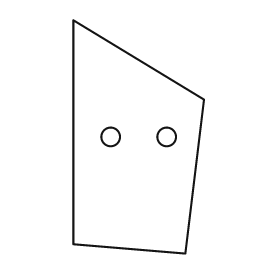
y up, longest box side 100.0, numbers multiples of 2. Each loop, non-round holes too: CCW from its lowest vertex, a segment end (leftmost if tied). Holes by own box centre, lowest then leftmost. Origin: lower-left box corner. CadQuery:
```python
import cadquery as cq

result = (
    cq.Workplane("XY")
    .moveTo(48.0, 0.0)
    .lineTo(56.0, 66.0)
    .lineTo(0.0, 100.0)
    .lineTo(0.0, 4.0)
    .close()
    .moveTo(16.0, 50.0)
    .circle(4.0)
    .moveTo(40.0, 50.0)
    .circle(4.0)
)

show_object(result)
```